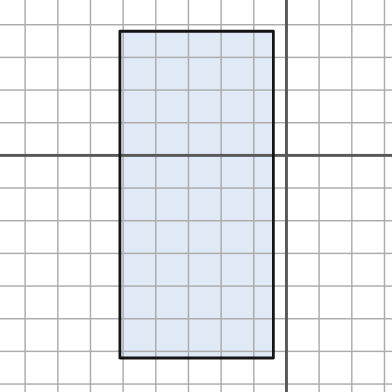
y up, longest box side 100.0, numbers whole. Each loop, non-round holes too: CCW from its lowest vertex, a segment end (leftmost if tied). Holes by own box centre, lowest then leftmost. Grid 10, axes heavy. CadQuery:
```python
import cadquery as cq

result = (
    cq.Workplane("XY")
    .moveTo(-51.0, -62.0)
    .lineTo(-4.0, -62.0)
    .lineTo(-4.0, 38.0)
    .lineTo(-51.0, 38.0)
    .close()
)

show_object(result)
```